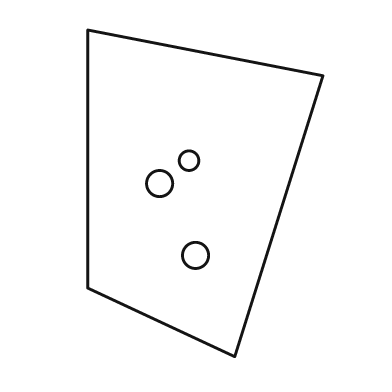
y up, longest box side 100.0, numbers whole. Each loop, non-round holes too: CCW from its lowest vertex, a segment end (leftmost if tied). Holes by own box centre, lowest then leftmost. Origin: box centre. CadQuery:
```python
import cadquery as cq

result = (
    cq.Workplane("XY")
    .moveTo(9.0, -50.0)
    .lineTo(36.0, 36.0)
    .lineTo(-36.0, 50.0)
    .lineTo(-36.0, -29.0)
    .close()
    .moveTo(-3.0, -19.0)
    .circle(4.0)
    .moveTo(-14.0, 3.0)
    .circle(4.0)
    .moveTo(-5.0, 10.0)
    .circle(3.0)
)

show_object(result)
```